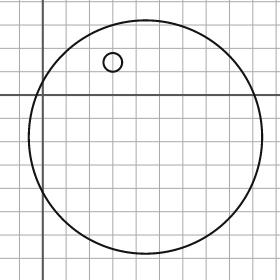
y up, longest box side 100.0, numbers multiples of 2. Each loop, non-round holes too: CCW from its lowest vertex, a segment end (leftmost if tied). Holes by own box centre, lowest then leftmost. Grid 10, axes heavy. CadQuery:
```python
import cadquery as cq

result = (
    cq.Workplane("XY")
    .moveTo(44.0, -18.0)
    .circle(50.0)
    .moveTo(30.0, 14.0)
    .circle(4.0)
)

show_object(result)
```